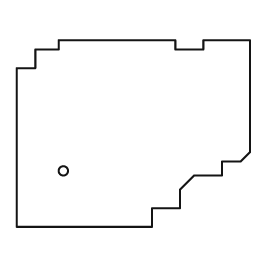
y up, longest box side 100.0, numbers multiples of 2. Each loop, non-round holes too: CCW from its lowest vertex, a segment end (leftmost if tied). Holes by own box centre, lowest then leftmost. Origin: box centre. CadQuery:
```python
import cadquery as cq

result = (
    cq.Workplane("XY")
    .moveTo(-50.0, -40.0)
    .lineTo(8.0, -40.0)
    .lineTo(8.0, -32.0)
    .lineTo(20.0, -32.0)
    .lineTo(20.0, -24.0)
    .lineTo(26.0, -18.0)
    .lineTo(38.0, -18.0)
    .lineTo(38.0, -12.0)
    .lineTo(46.0, -12.0)
    .lineTo(50.0, -8.0)
    .lineTo(50.0, 40.0)
    .lineTo(30.0, 40.0)
    .lineTo(30.0, 36.0)
    .lineTo(18.0, 36.0)
    .lineTo(18.0, 40.0)
    .lineTo(-32.0, 40.0)
    .lineTo(-32.0, 36.0)
    .lineTo(-42.0, 36.0)
    .lineTo(-42.0, 28.0)
    .lineTo(-50.0, 28.0)
    .close()
    .moveTo(-30.0, -16.0)
    .circle(2.0)
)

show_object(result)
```